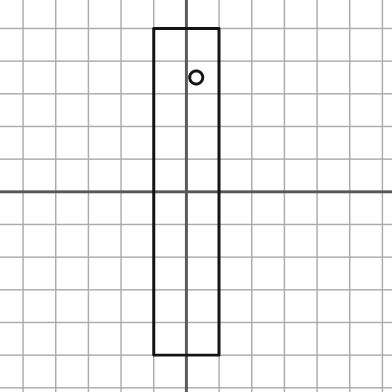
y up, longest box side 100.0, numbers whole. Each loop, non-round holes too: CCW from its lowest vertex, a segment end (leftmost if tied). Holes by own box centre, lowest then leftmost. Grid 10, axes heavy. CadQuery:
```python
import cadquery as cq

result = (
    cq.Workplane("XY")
    .moveTo(-10.0, -50.0)
    .lineTo(10.0, -50.0)
    .lineTo(10.0, 50.0)
    .lineTo(-10.0, 50.0)
    .close()
    .moveTo(3.0, 35.0)
    .circle(2.0)
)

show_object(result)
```